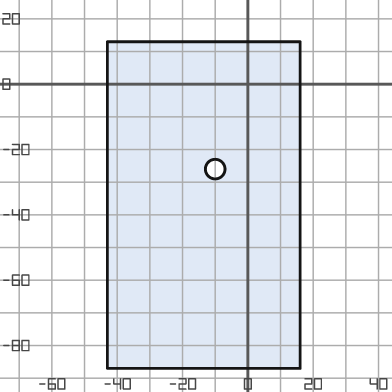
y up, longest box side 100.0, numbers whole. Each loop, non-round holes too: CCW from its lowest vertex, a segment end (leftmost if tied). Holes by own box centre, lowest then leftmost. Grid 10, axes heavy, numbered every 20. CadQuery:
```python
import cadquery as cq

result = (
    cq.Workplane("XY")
    .moveTo(-43.0, -87.0)
    .lineTo(16.0, -87.0)
    .lineTo(16.0, 13.0)
    .lineTo(-43.0, 13.0)
    .close()
    .moveTo(-10.0, -26.0)
    .circle(3.0)
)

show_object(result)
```